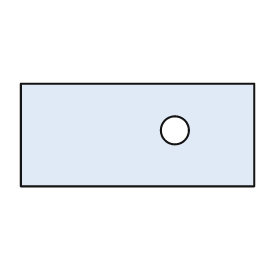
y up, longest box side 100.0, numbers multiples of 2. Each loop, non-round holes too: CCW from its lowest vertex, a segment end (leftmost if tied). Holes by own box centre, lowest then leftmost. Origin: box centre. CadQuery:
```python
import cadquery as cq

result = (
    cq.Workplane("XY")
    .moveTo(-50.0, -22.0)
    .lineTo(50.0, -22.0)
    .lineTo(50.0, 22.0)
    .lineTo(-50.0, 22.0)
    .close()
    .moveTo(16.0, 2.0)
    .circle(6.0)
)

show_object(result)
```